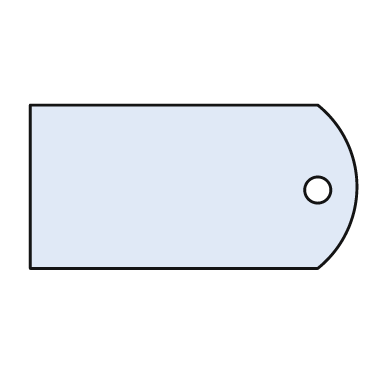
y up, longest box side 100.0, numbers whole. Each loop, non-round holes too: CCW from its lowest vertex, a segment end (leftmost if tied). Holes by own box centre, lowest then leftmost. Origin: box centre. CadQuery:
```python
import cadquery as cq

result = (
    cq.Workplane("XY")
    .moveTo(-50.0, -25.0)
    .lineTo(38.0, -25.0)
    .threePointArc((50.0, 0.0), (38.0, 25.0))
    .lineTo(-50.0, 25.0)
    .close()
    .moveTo(38.0, -1.0)
    .circle(4.0)
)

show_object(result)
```